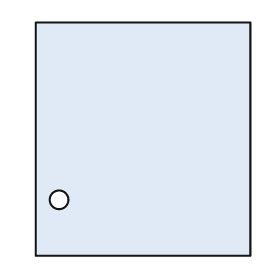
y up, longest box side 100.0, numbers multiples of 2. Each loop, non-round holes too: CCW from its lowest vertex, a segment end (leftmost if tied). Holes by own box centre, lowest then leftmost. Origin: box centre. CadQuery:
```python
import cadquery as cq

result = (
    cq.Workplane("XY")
    .moveTo(-46.0, -50.0)
    .lineTo(46.0, -50.0)
    .lineTo(46.0, 50.0)
    .lineTo(-46.0, 50.0)
    .close()
    .moveTo(-36.0, -26.0)
    .circle(4.0)
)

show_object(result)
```